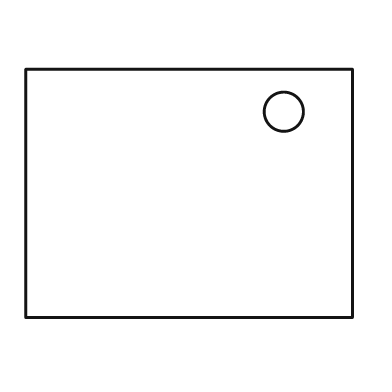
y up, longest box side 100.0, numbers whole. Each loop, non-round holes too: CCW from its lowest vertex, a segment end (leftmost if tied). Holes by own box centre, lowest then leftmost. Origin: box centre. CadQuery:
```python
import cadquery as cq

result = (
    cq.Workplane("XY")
    .moveTo(-50.0, -38.0)
    .lineTo(50.0, -38.0)
    .lineTo(50.0, 38.0)
    .lineTo(-50.0, 38.0)
    .close()
    .moveTo(29.0, 25.0)
    .circle(6.0)
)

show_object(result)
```